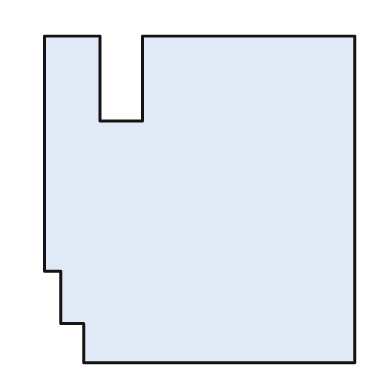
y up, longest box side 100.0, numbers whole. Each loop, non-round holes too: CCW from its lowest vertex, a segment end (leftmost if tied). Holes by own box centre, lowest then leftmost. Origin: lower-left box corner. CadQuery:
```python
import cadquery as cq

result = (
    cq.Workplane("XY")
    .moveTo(12.0, 0.0)
    .lineTo(95.0, 0.0)
    .lineTo(95.0, 100.0)
    .lineTo(30.0, 100.0)
    .lineTo(30.0, 74.0)
    .lineTo(17.0, 74.0)
    .lineTo(17.0, 100.0)
    .lineTo(0.0, 100.0)
    .lineTo(0.0, 28.0)
    .lineTo(5.0, 28.0)
    .lineTo(5.0, 12.0)
    .lineTo(12.0, 12.0)
    .close()
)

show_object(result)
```